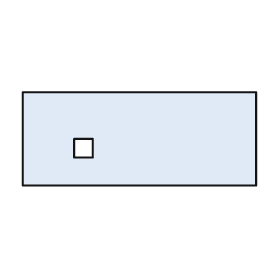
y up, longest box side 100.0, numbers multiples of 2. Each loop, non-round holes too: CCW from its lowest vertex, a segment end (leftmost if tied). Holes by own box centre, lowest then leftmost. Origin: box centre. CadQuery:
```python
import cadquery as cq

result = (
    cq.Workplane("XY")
    .moveTo(-50.0, -20.0)
    .lineTo(50.0, -20.0)
    .lineTo(50.0, 20.0)
    .lineTo(-50.0, 20.0)
    .close()
    .moveTo(-28.0, -8.0)
    .lineTo(-20.0, -8.0)
    .lineTo(-20.0, 0.0)
    .lineTo(-28.0, 0.0)
    .close()
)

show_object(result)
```